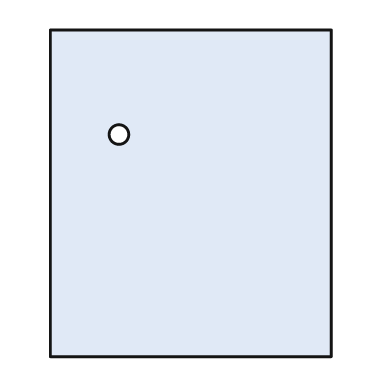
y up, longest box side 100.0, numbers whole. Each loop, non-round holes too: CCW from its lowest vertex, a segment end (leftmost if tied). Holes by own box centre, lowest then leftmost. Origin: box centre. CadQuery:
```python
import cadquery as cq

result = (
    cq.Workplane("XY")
    .moveTo(-43.0, -50.0)
    .lineTo(43.0, -50.0)
    .lineTo(43.0, 50.0)
    .lineTo(-43.0, 50.0)
    .close()
    .moveTo(-22.0, 18.0)
    .circle(3.0)
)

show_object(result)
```